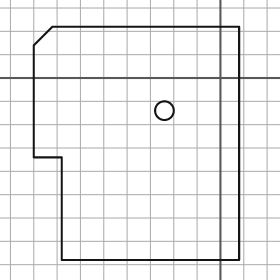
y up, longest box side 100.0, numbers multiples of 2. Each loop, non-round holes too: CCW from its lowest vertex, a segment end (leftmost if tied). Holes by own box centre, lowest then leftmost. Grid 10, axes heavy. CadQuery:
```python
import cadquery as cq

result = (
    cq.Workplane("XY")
    .moveTo(-68.0, -78.0)
    .lineTo(8.0, -78.0)
    .lineTo(8.0, 22.0)
    .lineTo(-72.0, 22.0)
    .lineTo(-80.0, 14.0)
    .lineTo(-80.0, -34.0)
    .lineTo(-68.0, -34.0)
    .close()
    .moveTo(-24.0, -14.0)
    .circle(4.0)
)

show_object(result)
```